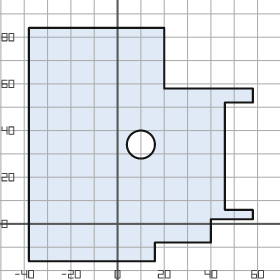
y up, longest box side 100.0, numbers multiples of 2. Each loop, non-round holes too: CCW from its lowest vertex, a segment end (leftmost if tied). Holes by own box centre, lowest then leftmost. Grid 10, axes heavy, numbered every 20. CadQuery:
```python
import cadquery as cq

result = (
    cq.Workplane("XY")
    .moveTo(-38.0, -16.0)
    .lineTo(16.0, -16.0)
    .lineTo(16.0, -8.0)
    .lineTo(40.0, -8.0)
    .lineTo(40.0, 2.0)
    .lineTo(58.0, 2.0)
    .lineTo(58.0, 6.0)
    .lineTo(46.0, 6.0)
    .lineTo(46.0, 52.0)
    .lineTo(58.0, 52.0)
    .lineTo(58.0, 58.0)
    .lineTo(20.0, 58.0)
    .lineTo(20.0, 84.0)
    .lineTo(-38.0, 84.0)
    .close()
    .moveTo(10.0, 34.0)
    .circle(6.0)
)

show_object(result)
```